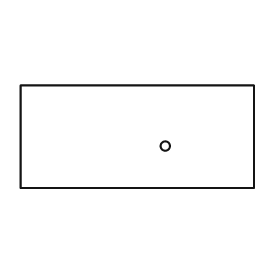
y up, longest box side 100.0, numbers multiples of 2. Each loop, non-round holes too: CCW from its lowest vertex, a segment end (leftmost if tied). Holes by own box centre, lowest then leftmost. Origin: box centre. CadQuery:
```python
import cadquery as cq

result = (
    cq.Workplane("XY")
    .moveTo(-50.0, -22.0)
    .lineTo(50.0, -22.0)
    .lineTo(50.0, 22.0)
    .lineTo(-50.0, 22.0)
    .close()
    .moveTo(12.0, -4.0)
    .circle(2.0)
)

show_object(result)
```